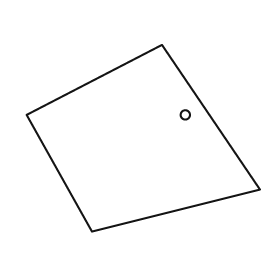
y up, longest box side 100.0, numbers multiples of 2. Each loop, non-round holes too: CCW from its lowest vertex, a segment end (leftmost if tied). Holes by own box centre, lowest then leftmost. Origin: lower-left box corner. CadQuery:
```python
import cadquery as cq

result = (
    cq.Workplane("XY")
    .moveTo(28.0, 0.0)
    .lineTo(100.0, 18.0)
    .lineTo(58.0, 80.0)
    .lineTo(0.0, 50.0)
    .close()
    .moveTo(68.0, 50.0)
    .circle(2.0)
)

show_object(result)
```